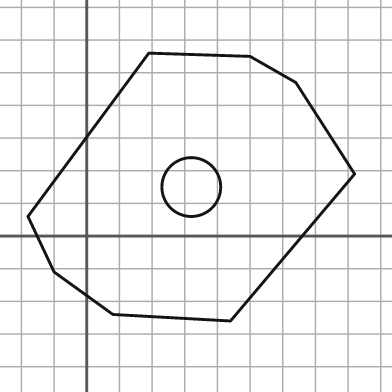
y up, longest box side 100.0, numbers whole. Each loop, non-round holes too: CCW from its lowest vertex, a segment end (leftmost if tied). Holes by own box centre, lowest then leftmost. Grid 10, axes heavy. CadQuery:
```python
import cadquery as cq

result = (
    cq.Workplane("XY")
    .moveTo(44.0, -26.0)
    .lineTo(82.0, 19.0)
    .lineTo(64.0, 47.0)
    .lineTo(50.0, 55.0)
    .lineTo(19.0, 56.0)
    .lineTo(-18.0, 6.0)
    .lineTo(-10.0, -11.0)
    .lineTo(8.0, -24.0)
    .close()
    .moveTo(32.0, 15.0)
    .circle(9.0)
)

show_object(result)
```